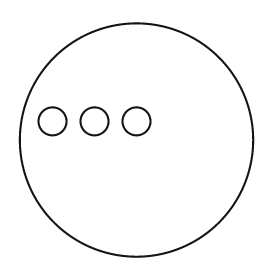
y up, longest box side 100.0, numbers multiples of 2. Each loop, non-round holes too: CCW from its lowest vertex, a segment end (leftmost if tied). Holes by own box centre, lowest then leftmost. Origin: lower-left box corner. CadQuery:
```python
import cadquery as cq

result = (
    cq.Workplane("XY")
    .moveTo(50.0, 50.0)
    .circle(50.0)
    .moveTo(14.0, 58.0)
    .circle(6.0)
    .moveTo(32.0, 58.0)
    .circle(6.0)
    .moveTo(50.0, 58.0)
    .circle(6.0)
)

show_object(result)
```